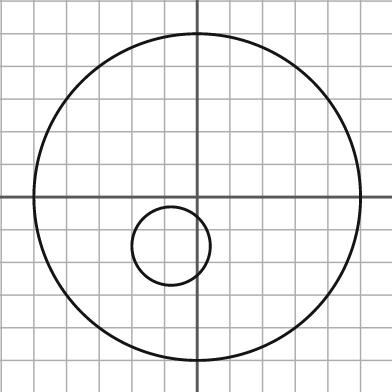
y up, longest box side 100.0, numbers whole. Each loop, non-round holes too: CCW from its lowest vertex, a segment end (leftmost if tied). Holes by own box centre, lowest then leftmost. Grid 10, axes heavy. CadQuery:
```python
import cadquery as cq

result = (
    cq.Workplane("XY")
    .moveTo(0.0, 0.0)
    .circle(50.0)
    .moveTo(-8.0, -15.0)
    .circle(12.0)
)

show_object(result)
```